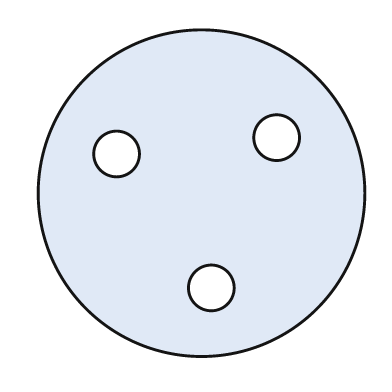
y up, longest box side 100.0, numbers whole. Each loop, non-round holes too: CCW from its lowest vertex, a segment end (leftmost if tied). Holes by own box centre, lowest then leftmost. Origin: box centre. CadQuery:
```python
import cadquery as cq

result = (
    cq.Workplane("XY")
    .moveTo(0.0, 0.0)
    .circle(50.0)
    .moveTo(3.0, -29.0)
    .circle(7.0)
    .moveTo(-26.0, 12.0)
    .circle(7.0)
    .moveTo(23.0, 17.0)
    .circle(7.0)
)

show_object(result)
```